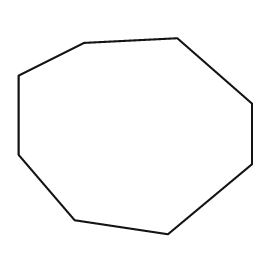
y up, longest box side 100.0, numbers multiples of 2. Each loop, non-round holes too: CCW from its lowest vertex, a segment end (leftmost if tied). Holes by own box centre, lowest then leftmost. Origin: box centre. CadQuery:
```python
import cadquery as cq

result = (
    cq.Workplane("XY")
    .moveTo(14.0, -42.0)
    .lineTo(50.0, -12.0)
    .lineTo(50.0, 14.0)
    .lineTo(18.0, 42.0)
    .lineTo(-22.0, 40.0)
    .lineTo(-50.0, 26.0)
    .lineTo(-50.0, -8.0)
    .lineTo(-26.0, -36.0)
    .close()
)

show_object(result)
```